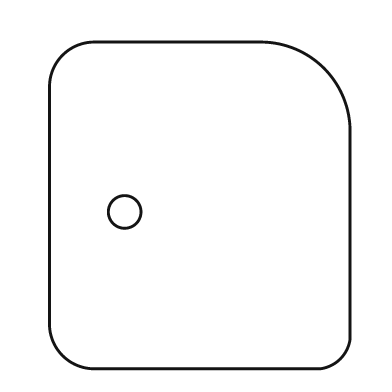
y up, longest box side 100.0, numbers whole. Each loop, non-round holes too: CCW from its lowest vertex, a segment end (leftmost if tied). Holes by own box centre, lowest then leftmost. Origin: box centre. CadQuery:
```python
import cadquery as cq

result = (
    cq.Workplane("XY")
    .moveTo(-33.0, -50.0)
    .lineTo(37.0, -50.0)
    .threePointArc((43.0, -47.0), (46.0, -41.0))
    .lineTo(46.0, 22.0)
    .threePointArc((38.0, 42.0), (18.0, 50.0))
    .lineTo(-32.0, 50.0)
    .threePointArc((-42.0, 46.0), (-46.0, 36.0))
    .lineTo(-46.0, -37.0)
    .threePointArc((-42.0, -46.0), (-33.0, -50.0))
    .close()
    .moveTo(-23.0, -2.0)
    .circle(5.0)
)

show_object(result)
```